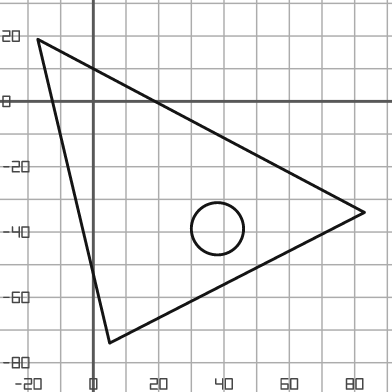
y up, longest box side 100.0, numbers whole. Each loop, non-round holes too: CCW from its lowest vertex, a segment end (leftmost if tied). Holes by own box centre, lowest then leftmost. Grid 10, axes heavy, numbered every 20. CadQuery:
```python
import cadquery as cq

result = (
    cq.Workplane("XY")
    .moveTo(5.0, -74.0)
    .lineTo(83.0, -34.0)
    .lineTo(-17.0, 19.0)
    .close()
    .moveTo(38.0, -39.0)
    .circle(8.0)
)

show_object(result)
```